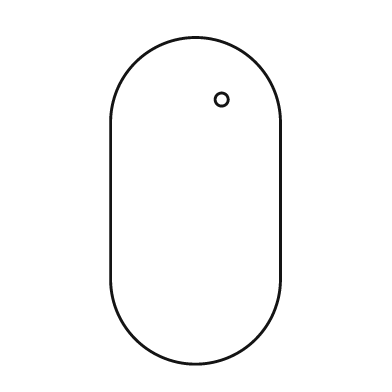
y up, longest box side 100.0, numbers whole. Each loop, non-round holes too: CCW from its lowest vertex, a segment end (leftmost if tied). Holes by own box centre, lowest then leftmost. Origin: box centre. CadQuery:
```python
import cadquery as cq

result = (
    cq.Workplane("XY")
    .moveTo(-26.0, -24.0)
    .threePointArc((0.0, -50.0), (26.0, -24.0))
    .lineTo(26.0, 24.0)
    .threePointArc((0.0, 50.0), (-26.0, 24.0))
    .close()
    .moveTo(8.0, 31.0)
    .circle(2.0)
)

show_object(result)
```